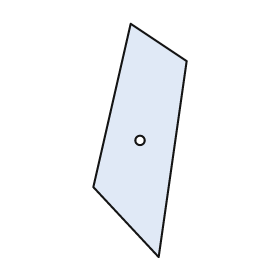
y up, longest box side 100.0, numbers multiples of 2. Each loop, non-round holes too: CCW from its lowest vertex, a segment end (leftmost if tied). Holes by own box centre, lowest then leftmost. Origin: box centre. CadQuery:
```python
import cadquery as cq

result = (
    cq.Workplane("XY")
    .moveTo(8.0, -50.0)
    .lineTo(20.0, 34.0)
    .lineTo(-4.0, 50.0)
    .lineTo(-20.0, -20.0)
    .close()
    .moveTo(0.0, 0.0)
    .circle(2.0)
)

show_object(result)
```